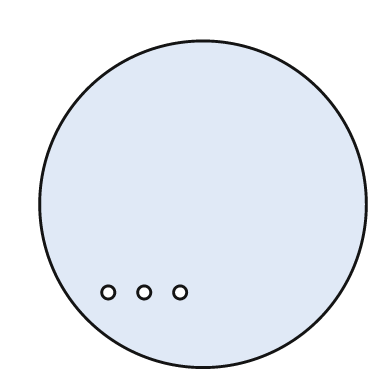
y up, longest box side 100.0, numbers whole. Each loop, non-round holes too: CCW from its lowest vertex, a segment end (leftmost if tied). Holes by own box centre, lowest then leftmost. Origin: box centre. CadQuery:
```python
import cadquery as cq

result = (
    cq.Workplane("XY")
    .moveTo(0.0, 0.0)
    .circle(50.0)
    .moveTo(-29.0, -27.0)
    .circle(2.0)
    .moveTo(-18.0, -27.0)
    .circle(2.0)
    .moveTo(-7.0, -27.0)
    .circle(2.0)
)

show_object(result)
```